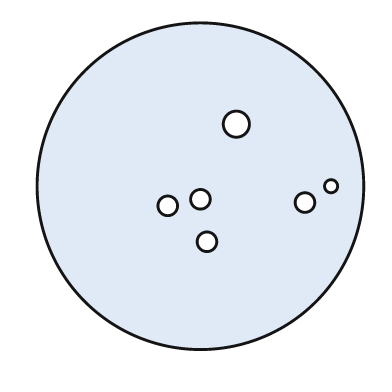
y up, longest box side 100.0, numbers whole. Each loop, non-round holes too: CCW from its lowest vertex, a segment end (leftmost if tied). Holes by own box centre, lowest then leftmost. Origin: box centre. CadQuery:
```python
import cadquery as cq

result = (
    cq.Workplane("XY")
    .moveTo(0.0, 0.0)
    .circle(50.0)
    .moveTo(2.0, -17.0)
    .circle(3.0)
    .moveTo(-10.0, -6.0)
    .circle(3.0)
    .moveTo(32.0, -5.0)
    .circle(3.0)
    .moveTo(0.0, -4.0)
    .circle(3.0)
    .moveTo(40.0, 0.0)
    .circle(2.0)
    .moveTo(11.0, 19.0)
    .circle(4.0)
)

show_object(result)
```